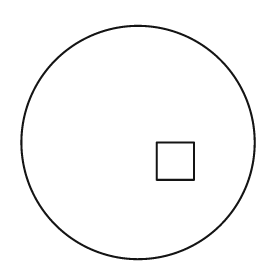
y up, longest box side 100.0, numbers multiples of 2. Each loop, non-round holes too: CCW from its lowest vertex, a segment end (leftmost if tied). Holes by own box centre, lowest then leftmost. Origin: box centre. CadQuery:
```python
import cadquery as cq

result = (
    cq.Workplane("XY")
    .moveTo(0.0, 0.0)
    .circle(50.0)
    .moveTo(8.0, -16.0)
    .lineTo(24.0, -16.0)
    .lineTo(24.0, 0.0)
    .lineTo(8.0, 0.0)
    .close()
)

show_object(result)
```